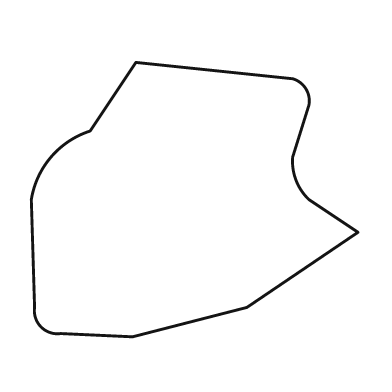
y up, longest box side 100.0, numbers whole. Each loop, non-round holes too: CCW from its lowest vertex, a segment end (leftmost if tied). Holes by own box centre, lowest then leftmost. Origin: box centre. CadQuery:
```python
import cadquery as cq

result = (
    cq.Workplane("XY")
    .moveTo(-19.0, -42.0)
    .lineTo(16.0, -33.0)
    .lineTo(50.0, -10.0)
    .lineTo(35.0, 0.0)
    .threePointArc((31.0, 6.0), (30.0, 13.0))
    .lineTo(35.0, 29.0)
    .threePointArc((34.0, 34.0), (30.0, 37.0))
    .lineTo(-18.0, 42.0)
    .lineTo(-32.0, 21.0)
    .threePointArc((-44.0, 13.0), (-50.0, 0.0))
    .lineTo(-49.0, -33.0)
    .threePointArc((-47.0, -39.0), (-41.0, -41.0))
    .close()
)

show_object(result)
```